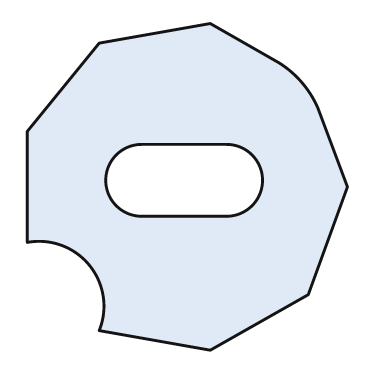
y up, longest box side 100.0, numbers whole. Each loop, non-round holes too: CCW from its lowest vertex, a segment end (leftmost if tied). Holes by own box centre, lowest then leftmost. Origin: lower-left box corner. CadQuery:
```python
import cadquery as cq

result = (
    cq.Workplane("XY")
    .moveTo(56.0, 0.0)
    .lineTo(86.0, 17.0)
    .lineTo(98.0, 50.0)
    .lineTo(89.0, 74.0)
    .threePointArc((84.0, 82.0), (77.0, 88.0))
    .lineTo(56.0, 100.0)
    .lineTo(22.0, 94.0)
    .lineTo(0.0, 67.0)
    .lineTo(0.0, 33.0)
    .threePointArc((19.0, 26.0), (22.0, 6.0))
    .close()
    .moveTo(35.0, 41.0)
    .lineTo(61.0, 41.0)
    .threePointArc((72.0, 52.0), (61.0, 63.0))
    .lineTo(35.0, 63.0)
    .threePointArc((24.0, 52.0), (35.0, 41.0))
    .close()
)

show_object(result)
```